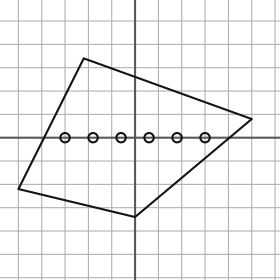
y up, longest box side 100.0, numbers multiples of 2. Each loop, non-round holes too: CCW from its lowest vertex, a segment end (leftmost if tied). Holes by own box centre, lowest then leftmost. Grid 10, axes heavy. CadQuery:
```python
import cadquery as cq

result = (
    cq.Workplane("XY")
    .moveTo(0.0, -34.0)
    .lineTo(50.0, 8.0)
    .lineTo(-22.0, 34.0)
    .lineTo(-50.0, -22.0)
    .close()
    .moveTo(-30.0, 0.0)
    .circle(2.0)
    .moveTo(-18.0, 0.0)
    .circle(2.0)
    .moveTo(-6.0, 0.0)
    .circle(2.0)
    .moveTo(6.0, 0.0)
    .circle(2.0)
    .moveTo(18.0, 0.0)
    .circle(2.0)
    .moveTo(30.0, 0.0)
    .circle(2.0)
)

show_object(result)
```